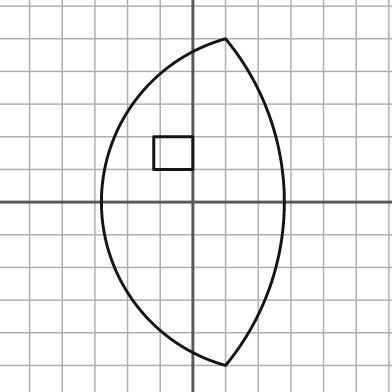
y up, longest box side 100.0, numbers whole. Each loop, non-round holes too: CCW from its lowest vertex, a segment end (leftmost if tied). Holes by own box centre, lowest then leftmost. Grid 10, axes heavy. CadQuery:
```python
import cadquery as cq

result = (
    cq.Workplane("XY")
    .moveTo(10.0, -50.0)
    .threePointArc((28.0, 0.0), (10.0, 50.0))
    .threePointArc((-28.0, 0.0), (10.0, -50.0))
    .close()
    .moveTo(-12.0, 10.0)
    .lineTo(0.0, 10.0)
    .lineTo(0.0, 20.0)
    .lineTo(-12.0, 20.0)
    .close()
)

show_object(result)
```